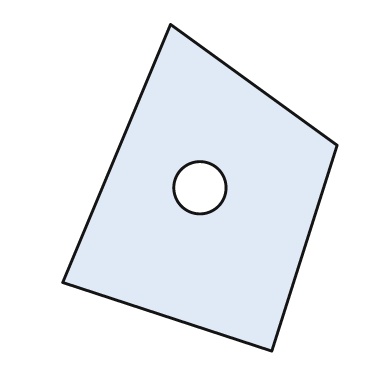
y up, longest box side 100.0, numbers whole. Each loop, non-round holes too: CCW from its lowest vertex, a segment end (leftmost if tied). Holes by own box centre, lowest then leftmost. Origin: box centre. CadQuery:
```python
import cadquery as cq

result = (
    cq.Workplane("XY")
    .moveTo(22.0, -50.0)
    .lineTo(42.0, 13.0)
    .lineTo(-9.0, 50.0)
    .lineTo(-42.0, -29.0)
    .close()
    .moveTo(0.0, 0.0)
    .circle(8.0)
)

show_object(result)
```